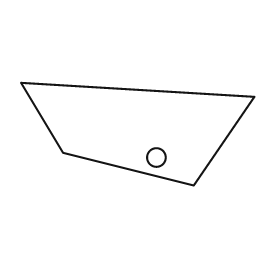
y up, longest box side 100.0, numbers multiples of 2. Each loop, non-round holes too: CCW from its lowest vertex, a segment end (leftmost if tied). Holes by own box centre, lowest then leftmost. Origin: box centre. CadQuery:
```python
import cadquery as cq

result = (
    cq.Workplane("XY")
    .moveTo(24.0, -22.0)
    .lineTo(50.0, 16.0)
    .lineTo(-50.0, 22.0)
    .lineTo(-32.0, -8.0)
    .close()
    .moveTo(8.0, -10.0)
    .circle(4.0)
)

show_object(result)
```